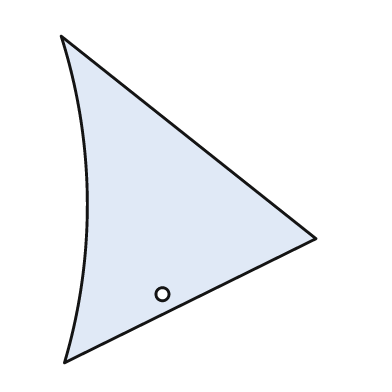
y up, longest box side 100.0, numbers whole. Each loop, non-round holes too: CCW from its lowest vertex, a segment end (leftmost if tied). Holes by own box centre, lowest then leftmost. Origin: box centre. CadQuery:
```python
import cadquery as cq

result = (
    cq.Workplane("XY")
    .moveTo(-38.0, -50.0)
    .lineTo(39.0, -12.0)
    .lineTo(-39.0, 50.0)
    .threePointArc((-31.0, 0.0), (-38.0, -50.0))
    .close()
    .moveTo(-8.0, -29.0)
    .circle(2.0)
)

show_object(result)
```